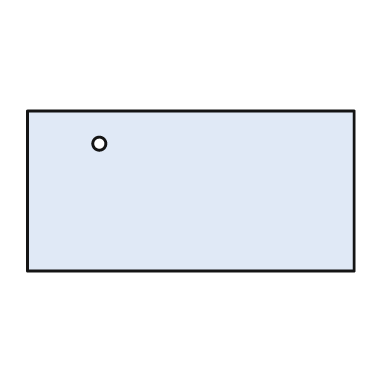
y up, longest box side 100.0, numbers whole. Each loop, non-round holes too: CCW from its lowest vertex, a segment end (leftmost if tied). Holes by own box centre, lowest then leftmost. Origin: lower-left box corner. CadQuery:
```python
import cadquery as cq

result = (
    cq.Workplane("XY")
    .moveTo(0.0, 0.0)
    .lineTo(100.0, 0.0)
    .lineTo(100.0, 49.0)
    .lineTo(0.0, 49.0)
    .close()
    .moveTo(22.0, 39.0)
    .circle(2.0)
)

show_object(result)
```